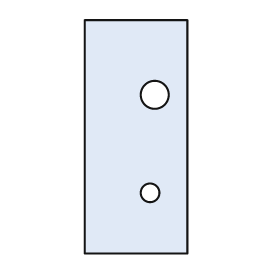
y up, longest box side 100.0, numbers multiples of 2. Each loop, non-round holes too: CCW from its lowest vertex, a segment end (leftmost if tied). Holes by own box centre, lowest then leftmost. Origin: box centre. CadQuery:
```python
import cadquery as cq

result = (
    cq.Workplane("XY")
    .moveTo(-22.0, -50.0)
    .lineTo(22.0, -50.0)
    .lineTo(22.0, 50.0)
    .lineTo(-22.0, 50.0)
    .close()
    .moveTo(6.0, -24.0)
    .circle(4.0)
    .moveTo(8.0, 18.0)
    .circle(6.0)
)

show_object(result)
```